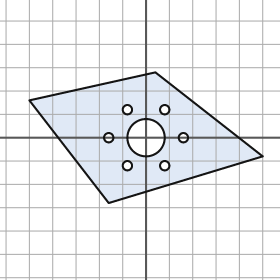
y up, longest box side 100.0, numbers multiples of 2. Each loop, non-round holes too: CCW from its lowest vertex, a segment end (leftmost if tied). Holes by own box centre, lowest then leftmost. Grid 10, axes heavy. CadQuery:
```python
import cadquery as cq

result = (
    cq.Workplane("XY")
    .moveTo(-16.0, -28.0)
    .lineTo(50.0, -8.0)
    .lineTo(4.0, 28.0)
    .lineTo(-50.0, 16.0)
    .close()
    .moveTo(-8.0, -12.0)
    .circle(2.0)
    .moveTo(8.0, -12.0)
    .circle(2.0)
    .moveTo(-16.0, 0.0)
    .circle(2.0)
    .moveTo(0.0, 0.0)
    .circle(8.0)
    .moveTo(16.0, 0.0)
    .circle(2.0)
    .moveTo(-8.0, 12.0)
    .circle(2.0)
    .moveTo(8.0, 12.0)
    .circle(2.0)
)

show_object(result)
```